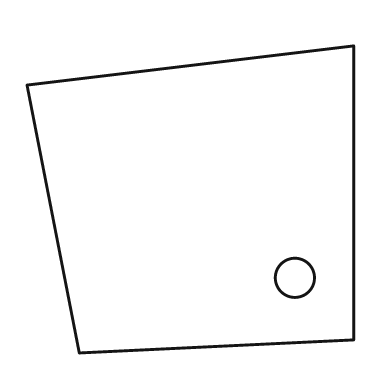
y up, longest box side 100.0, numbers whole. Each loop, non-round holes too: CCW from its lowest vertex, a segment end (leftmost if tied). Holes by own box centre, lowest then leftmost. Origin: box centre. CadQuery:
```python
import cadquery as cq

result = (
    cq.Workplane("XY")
    .moveTo(-34.0, -47.0)
    .lineTo(50.0, -43.0)
    .lineTo(50.0, 47.0)
    .lineTo(-50.0, 35.0)
    .close()
    .moveTo(32.0, -24.0)
    .circle(6.0)
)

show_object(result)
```